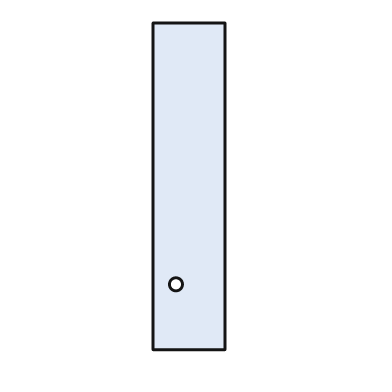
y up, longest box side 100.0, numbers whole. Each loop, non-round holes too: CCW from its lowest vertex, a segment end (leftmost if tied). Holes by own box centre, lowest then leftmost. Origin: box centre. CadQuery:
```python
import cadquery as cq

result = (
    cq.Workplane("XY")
    .moveTo(-11.0, -50.0)
    .lineTo(11.0, -50.0)
    .lineTo(11.0, 50.0)
    .lineTo(-11.0, 50.0)
    .close()
    .moveTo(-4.0, -30.0)
    .circle(2.0)
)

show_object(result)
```